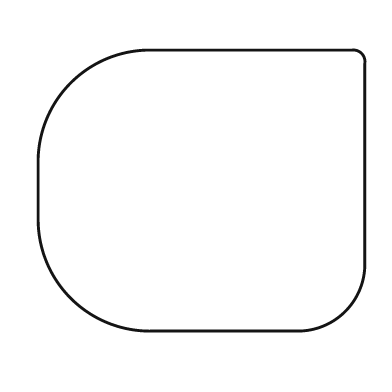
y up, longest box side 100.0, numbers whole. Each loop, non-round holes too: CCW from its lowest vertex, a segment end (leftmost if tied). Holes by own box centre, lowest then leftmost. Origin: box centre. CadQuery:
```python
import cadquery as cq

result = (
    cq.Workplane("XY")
    .moveTo(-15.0, -43.0)
    .lineTo(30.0, -43.0)
    .threePointArc((44.0, -37.0), (50.0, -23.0))
    .lineTo(50.0, 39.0)
    .threePointArc((49.0, 42.0), (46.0, 43.0))
    .lineTo(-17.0, 43.0)
    .threePointArc((-40.0, 33.0), (-50.0, 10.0))
    .lineTo(-50.0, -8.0)
    .threePointArc((-40.0, -33.0), (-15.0, -43.0))
    .close()
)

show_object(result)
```